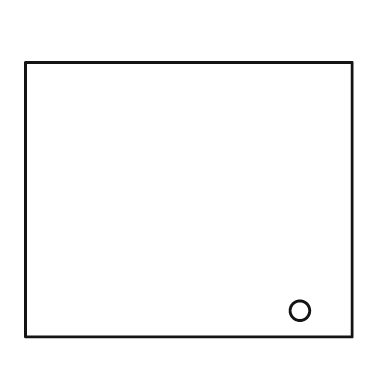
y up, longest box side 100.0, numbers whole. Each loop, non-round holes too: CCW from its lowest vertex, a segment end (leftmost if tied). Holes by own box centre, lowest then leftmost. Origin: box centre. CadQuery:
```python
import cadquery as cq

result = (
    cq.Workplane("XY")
    .moveTo(-50.0, -42.0)
    .lineTo(50.0, -42.0)
    .lineTo(50.0, 42.0)
    .lineTo(-50.0, 42.0)
    .close()
    .moveTo(34.0, -34.0)
    .circle(3.0)
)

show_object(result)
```